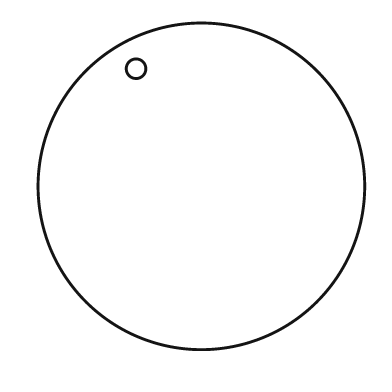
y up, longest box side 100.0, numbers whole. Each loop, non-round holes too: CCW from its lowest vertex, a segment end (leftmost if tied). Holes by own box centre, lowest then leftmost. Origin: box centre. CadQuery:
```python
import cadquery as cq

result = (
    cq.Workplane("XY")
    .moveTo(0.0, 0.0)
    .circle(50.0)
    .moveTo(-20.0, 36.0)
    .circle(3.0)
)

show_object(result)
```